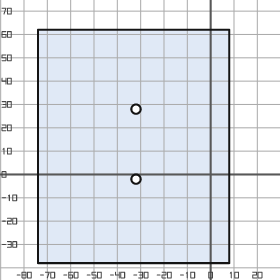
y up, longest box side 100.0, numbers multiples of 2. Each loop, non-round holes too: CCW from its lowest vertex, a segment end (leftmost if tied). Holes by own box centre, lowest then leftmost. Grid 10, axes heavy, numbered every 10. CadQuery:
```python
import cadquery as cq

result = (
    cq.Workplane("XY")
    .moveTo(-74.0, -38.0)
    .lineTo(8.0, -38.0)
    .lineTo(8.0, 62.0)
    .lineTo(-74.0, 62.0)
    .close()
    .moveTo(-32.0, -2.0)
    .circle(2.0)
    .moveTo(-32.0, 28.0)
    .circle(2.0)
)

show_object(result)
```